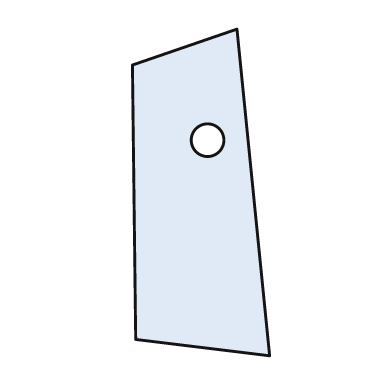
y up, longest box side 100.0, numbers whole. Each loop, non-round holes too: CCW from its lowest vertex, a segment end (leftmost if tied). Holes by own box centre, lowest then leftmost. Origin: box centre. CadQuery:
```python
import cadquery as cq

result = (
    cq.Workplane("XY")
    .moveTo(21.0, -50.0)
    .lineTo(11.0, 50.0)
    .lineTo(-21.0, 39.0)
    .lineTo(-20.0, -45.0)
    .close()
    .moveTo(2.0, 16.0)
    .circle(5.0)
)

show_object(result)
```